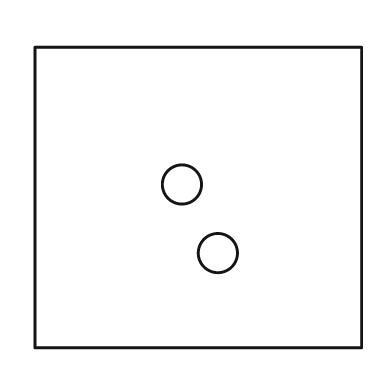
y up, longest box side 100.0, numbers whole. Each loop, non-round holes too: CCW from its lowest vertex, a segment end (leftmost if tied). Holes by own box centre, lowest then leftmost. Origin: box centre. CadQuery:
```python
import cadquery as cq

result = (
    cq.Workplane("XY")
    .moveTo(-50.0, -46.0)
    .lineTo(50.0, -46.0)
    .lineTo(50.0, 46.0)
    .lineTo(-50.0, 46.0)
    .close()
    .moveTo(6.0, -17.0)
    .circle(6.0)
    .moveTo(-5.0, 4.0)
    .circle(6.0)
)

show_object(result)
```